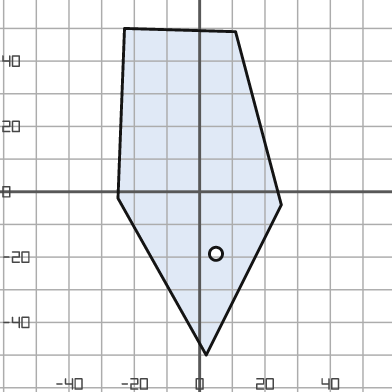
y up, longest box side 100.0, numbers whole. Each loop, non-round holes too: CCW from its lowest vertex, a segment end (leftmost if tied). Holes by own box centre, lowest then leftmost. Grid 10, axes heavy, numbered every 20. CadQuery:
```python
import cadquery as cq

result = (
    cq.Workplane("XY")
    .moveTo(2.0, -50.0)
    .lineTo(25.0, -4.0)
    .lineTo(11.0, 49.0)
    .lineTo(-23.0, 50.0)
    .lineTo(-25.0, -2.0)
    .close()
    .moveTo(5.0, -19.0)
    .circle(2.0)
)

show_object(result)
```